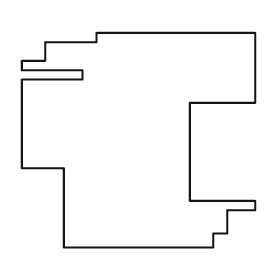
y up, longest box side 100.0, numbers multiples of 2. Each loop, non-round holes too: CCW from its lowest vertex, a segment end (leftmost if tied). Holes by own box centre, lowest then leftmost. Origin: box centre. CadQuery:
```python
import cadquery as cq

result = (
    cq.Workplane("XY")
    .moveTo(-32.0, -46.0)
    .lineTo(32.0, -46.0)
    .lineTo(32.0, -40.0)
    .lineTo(38.0, -40.0)
    .lineTo(38.0, -30.0)
    .lineTo(50.0, -30.0)
    .lineTo(50.0, -26.0)
    .lineTo(22.0, -26.0)
    .lineTo(22.0, 16.0)
    .lineTo(50.0, 16.0)
    .lineTo(50.0, 46.0)
    .lineTo(-18.0, 46.0)
    .lineTo(-18.0, 42.0)
    .lineTo(-40.0, 42.0)
    .lineTo(-40.0, 34.0)
    .lineTo(-50.0, 34.0)
    .lineTo(-50.0, 30.0)
    .lineTo(-24.0, 30.0)
    .lineTo(-24.0, 26.0)
    .lineTo(-50.0, 26.0)
    .lineTo(-50.0, -12.0)
    .lineTo(-32.0, -12.0)
    .close()
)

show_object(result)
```